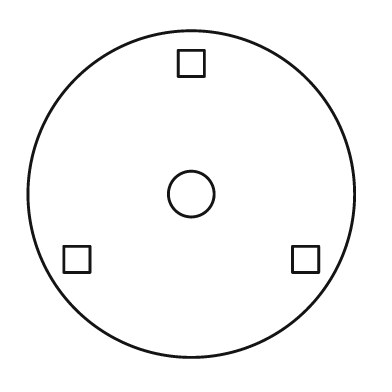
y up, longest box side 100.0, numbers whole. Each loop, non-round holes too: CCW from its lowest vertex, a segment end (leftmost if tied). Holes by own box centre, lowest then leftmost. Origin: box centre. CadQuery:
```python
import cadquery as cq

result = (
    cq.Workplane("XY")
    .moveTo(0.0, 0.0)
    .circle(50.0)
    .moveTo(-39.0, -24.0)
    .lineTo(-31.0, -24.0)
    .lineTo(-31.0, -16.0)
    .lineTo(-39.0, -16.0)
    .close()
    .moveTo(31.0, -24.0)
    .lineTo(39.0, -24.0)
    .lineTo(39.0, -16.0)
    .lineTo(31.0, -16.0)
    .close()
    .moveTo(0.0, 0.0)
    .circle(7.0)
    .moveTo(-4.0, 36.0)
    .lineTo(4.0, 36.0)
    .lineTo(4.0, 44.0)
    .lineTo(-4.0, 44.0)
    .close()
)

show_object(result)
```